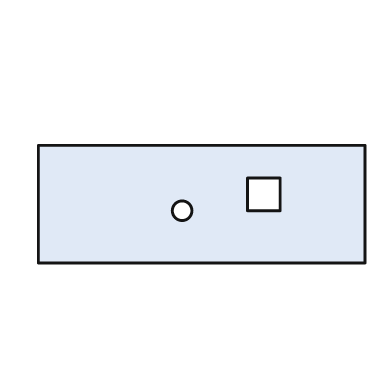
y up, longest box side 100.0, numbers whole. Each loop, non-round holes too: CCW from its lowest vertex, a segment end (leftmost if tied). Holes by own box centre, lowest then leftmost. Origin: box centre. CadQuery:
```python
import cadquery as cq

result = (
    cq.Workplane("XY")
    .moveTo(-50.0, -18.0)
    .lineTo(50.0, -18.0)
    .lineTo(50.0, 18.0)
    .lineTo(-50.0, 18.0)
    .close()
    .moveTo(-6.0, -2.0)
    .circle(3.0)
    .moveTo(14.0, -2.0)
    .lineTo(24.0, -2.0)
    .lineTo(24.0, 8.0)
    .lineTo(14.0, 8.0)
    .close()
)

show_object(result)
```